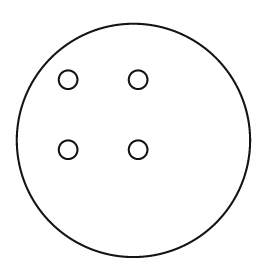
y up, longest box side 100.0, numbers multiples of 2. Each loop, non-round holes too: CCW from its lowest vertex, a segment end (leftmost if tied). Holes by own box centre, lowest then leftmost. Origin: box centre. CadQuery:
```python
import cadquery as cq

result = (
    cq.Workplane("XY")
    .moveTo(0.0, 0.0)
    .circle(50.0)
    .moveTo(-28.0, -4.0)
    .circle(4.0)
    .moveTo(2.0, -4.0)
    .circle(4.0)
    .moveTo(-28.0, 26.0)
    .circle(4.0)
    .moveTo(2.0, 26.0)
    .circle(4.0)
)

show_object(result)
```